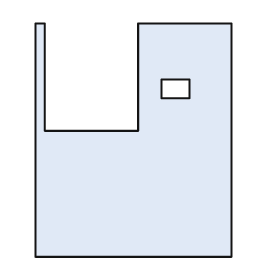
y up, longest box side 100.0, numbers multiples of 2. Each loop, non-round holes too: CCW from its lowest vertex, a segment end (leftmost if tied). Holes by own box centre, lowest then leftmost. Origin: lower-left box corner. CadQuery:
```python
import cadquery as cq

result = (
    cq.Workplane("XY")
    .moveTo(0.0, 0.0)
    .lineTo(84.0, 0.0)
    .lineTo(84.0, 100.0)
    .lineTo(44.0, 100.0)
    .lineTo(44.0, 54.0)
    .lineTo(4.0, 54.0)
    .lineTo(4.0, 100.0)
    .lineTo(0.0, 100.0)
    .close()
    .moveTo(54.0, 68.0)
    .lineTo(66.0, 68.0)
    .lineTo(66.0, 76.0)
    .lineTo(54.0, 76.0)
    .close()
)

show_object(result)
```